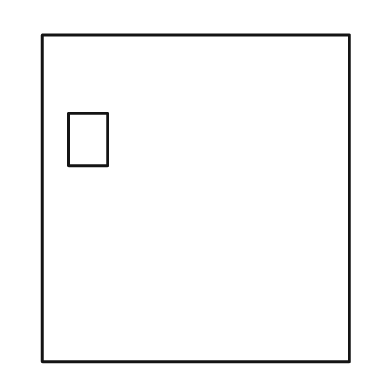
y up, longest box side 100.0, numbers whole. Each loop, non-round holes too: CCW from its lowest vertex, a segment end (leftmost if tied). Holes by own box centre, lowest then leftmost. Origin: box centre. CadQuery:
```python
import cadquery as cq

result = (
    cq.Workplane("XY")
    .moveTo(-47.0, -50.0)
    .lineTo(47.0, -50.0)
    .lineTo(47.0, 50.0)
    .lineTo(-47.0, 50.0)
    .close()
    .moveTo(-39.0, 10.0)
    .lineTo(-27.0, 10.0)
    .lineTo(-27.0, 26.0)
    .lineTo(-39.0, 26.0)
    .close()
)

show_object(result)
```